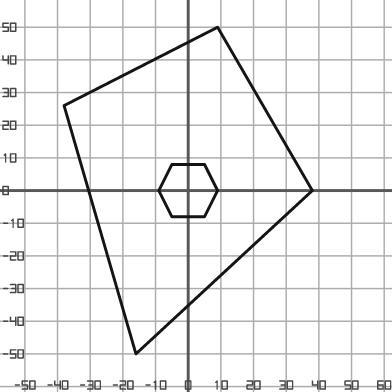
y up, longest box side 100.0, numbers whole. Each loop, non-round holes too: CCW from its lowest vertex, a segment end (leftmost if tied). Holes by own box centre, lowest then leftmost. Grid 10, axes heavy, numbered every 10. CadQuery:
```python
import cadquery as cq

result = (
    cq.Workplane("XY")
    .moveTo(-16.0, -50.0)
    .lineTo(38.0, 0.0)
    .lineTo(9.0, 50.0)
    .lineTo(-38.0, 26.0)
    .close()
    .moveTo(-5.0, -8.0)
    .lineTo(5.0, -8.0)
    .lineTo(9.0, 0.0)
    .lineTo(5.0, 8.0)
    .lineTo(-5.0, 8.0)
    .lineTo(-9.0, 0.0)
    .close()
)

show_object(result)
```